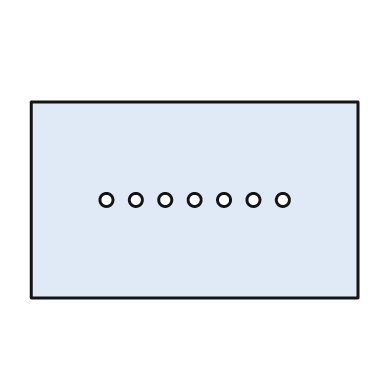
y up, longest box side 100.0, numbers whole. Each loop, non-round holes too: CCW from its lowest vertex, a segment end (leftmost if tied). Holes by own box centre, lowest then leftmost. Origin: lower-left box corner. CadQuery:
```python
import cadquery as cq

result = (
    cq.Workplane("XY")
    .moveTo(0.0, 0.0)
    .lineTo(100.0, 0.0)
    .lineTo(100.0, 60.0)
    .lineTo(0.0, 60.0)
    .close()
    .moveTo(23.0, 30.0)
    .circle(2.0)
    .moveTo(32.0, 30.0)
    .circle(2.0)
    .moveTo(41.0, 30.0)
    .circle(2.0)
    .moveTo(50.0, 30.0)
    .circle(2.0)
    .moveTo(59.0, 30.0)
    .circle(2.0)
    .moveTo(68.0, 30.0)
    .circle(2.0)
    .moveTo(77.0, 30.0)
    .circle(2.0)
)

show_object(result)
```